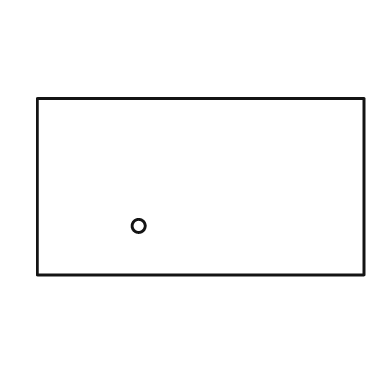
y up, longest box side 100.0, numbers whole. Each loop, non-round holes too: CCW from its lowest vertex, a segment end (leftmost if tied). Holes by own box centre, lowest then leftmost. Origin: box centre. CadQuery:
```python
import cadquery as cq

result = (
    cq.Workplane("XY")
    .moveTo(-50.0, -27.0)
    .lineTo(50.0, -27.0)
    .lineTo(50.0, 27.0)
    .lineTo(-50.0, 27.0)
    .close()
    .moveTo(-19.0, -12.0)
    .circle(2.0)
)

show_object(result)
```